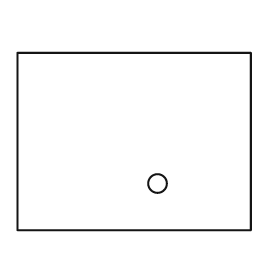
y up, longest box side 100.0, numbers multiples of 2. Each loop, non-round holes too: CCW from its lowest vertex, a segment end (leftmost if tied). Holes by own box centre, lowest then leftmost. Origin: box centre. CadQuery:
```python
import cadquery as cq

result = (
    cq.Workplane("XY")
    .moveTo(-50.0, -38.0)
    .lineTo(50.0, -38.0)
    .lineTo(50.0, 38.0)
    .lineTo(-50.0, 38.0)
    .close()
    .moveTo(10.0, -18.0)
    .circle(4.0)
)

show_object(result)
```